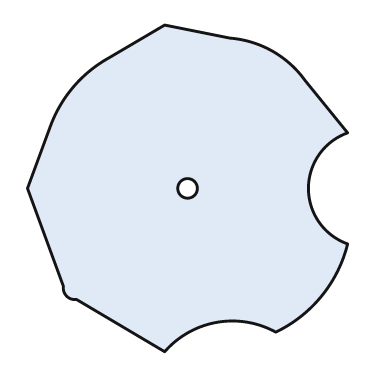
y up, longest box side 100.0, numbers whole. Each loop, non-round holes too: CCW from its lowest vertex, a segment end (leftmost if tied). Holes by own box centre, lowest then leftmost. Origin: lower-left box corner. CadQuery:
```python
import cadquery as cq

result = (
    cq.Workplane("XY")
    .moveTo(42.0, 0.0)
    .threePointArc((58.0, 9.0), (76.0, 6.0))
    .threePointArc((90.0, 17.0), (98.0, 33.0))
    .threePointArc((86.0, 50.0), (98.0, 67.0))
    .lineTo(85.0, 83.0)
    .threePointArc((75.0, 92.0), (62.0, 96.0))
    .lineTo(42.0, 100.0)
    .lineTo(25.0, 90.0)
    .threePointArc((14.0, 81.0), (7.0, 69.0))
    .lineTo(0.0, 50.0)
    .lineTo(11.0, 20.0)
    .threePointArc((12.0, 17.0), (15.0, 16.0))
    .close()
    .moveTo(49.0, 50.0)
    .circle(3.0)
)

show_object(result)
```